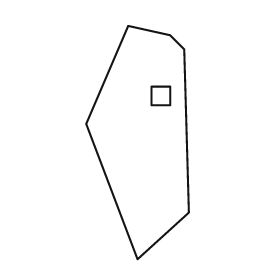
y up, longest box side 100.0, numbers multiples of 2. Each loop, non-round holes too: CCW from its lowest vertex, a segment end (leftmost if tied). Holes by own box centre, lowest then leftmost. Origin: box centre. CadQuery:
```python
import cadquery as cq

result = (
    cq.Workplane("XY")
    .moveTo(0.0, -50.0)
    .lineTo(22.0, -30.0)
    .lineTo(20.0, 40.0)
    .lineTo(14.0, 46.0)
    .lineTo(-4.0, 50.0)
    .lineTo(-22.0, 8.0)
    .close()
    .moveTo(6.0, 16.0)
    .lineTo(14.0, 16.0)
    .lineTo(14.0, 24.0)
    .lineTo(6.0, 24.0)
    .close()
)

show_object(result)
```